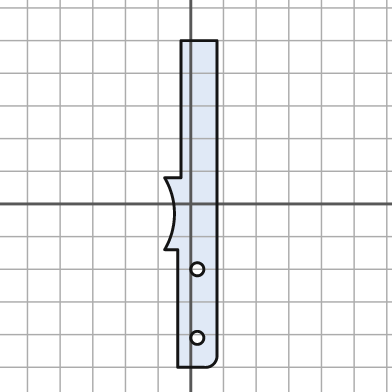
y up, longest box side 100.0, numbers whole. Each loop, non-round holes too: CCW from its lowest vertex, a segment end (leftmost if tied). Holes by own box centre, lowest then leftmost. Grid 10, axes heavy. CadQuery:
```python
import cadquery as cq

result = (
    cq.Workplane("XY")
    .moveTo(-4.0, -50.0)
    .lineTo(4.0, -50.0)
    .threePointArc((7.0, -49.0), (8.0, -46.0))
    .lineTo(8.0, 50.0)
    .lineTo(-3.0, 50.0)
    .lineTo(-3.0, 8.0)
    .lineTo(-8.0, 8.0)
    .threePointArc((-5.0, -3.0), (-8.0, -14.0))
    .lineTo(-4.0, -14.0)
    .close()
    .moveTo(2.0, -41.0)
    .circle(2.0)
    .moveTo(2.0, -20.0)
    .circle(2.0)
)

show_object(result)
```